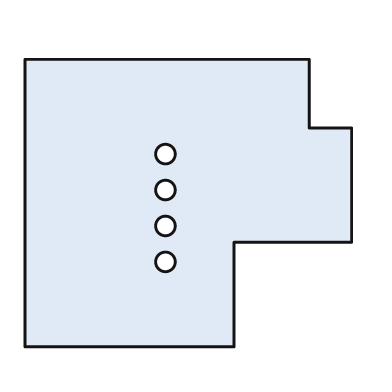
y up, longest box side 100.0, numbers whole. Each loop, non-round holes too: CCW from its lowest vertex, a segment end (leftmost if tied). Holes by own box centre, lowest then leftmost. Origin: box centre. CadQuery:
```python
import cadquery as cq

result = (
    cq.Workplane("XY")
    .moveTo(-50.0, -44.0)
    .lineTo(14.0, -44.0)
    .lineTo(14.0, -12.0)
    .lineTo(50.0, -12.0)
    .lineTo(50.0, 23.0)
    .lineTo(37.0, 23.0)
    .lineTo(37.0, 44.0)
    .lineTo(-50.0, 44.0)
    .close()
    .moveTo(-7.0, -18.0)
    .circle(3.0)
    .moveTo(-7.0, -7.0)
    .circle(3.0)
    .moveTo(-7.0, 4.0)
    .circle(3.0)
    .moveTo(-7.0, 15.0)
    .circle(3.0)
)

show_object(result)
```